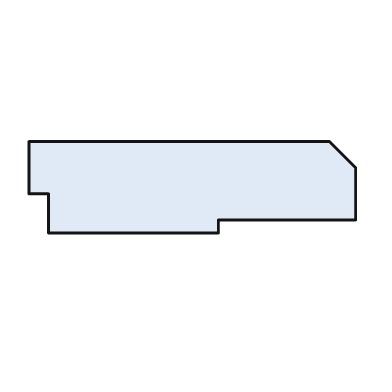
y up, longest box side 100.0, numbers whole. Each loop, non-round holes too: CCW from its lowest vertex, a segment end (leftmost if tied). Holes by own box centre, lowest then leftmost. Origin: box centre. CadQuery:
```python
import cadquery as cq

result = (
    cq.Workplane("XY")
    .moveTo(-44.0, -14.0)
    .lineTo(8.0, -14.0)
    .lineTo(8.0, -10.0)
    .lineTo(50.0, -10.0)
    .lineTo(50.0, 6.0)
    .lineTo(42.0, 14.0)
    .lineTo(-50.0, 14.0)
    .lineTo(-50.0, -2.0)
    .lineTo(-44.0, -2.0)
    .close()
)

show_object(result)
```